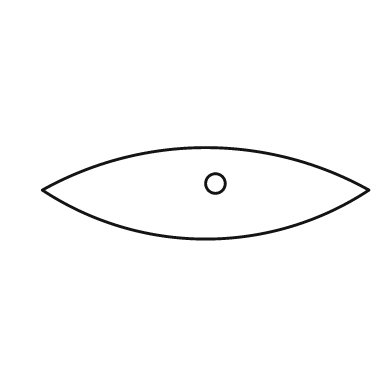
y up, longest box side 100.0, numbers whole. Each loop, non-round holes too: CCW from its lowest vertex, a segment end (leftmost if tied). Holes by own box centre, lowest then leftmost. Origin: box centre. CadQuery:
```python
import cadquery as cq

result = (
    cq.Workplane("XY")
    .moveTo(-50.0, 1.0)
    .threePointArc((0.0, -14.0), (50.0, 1.0))
    .threePointArc((0.0, 14.0), (-50.0, 1.0))
    .close()
    .moveTo(3.0, 3.0)
    .circle(3.0)
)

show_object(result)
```